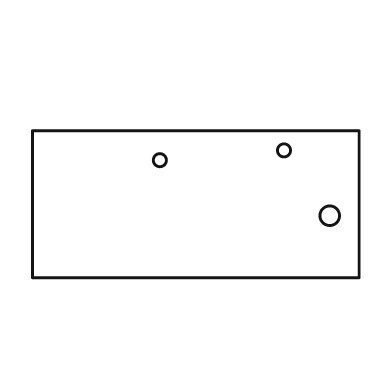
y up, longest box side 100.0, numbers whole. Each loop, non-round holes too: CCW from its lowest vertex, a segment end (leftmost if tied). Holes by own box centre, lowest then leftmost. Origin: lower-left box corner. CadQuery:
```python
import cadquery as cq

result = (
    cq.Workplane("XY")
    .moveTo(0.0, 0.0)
    .lineTo(100.0, 0.0)
    .lineTo(100.0, 45.0)
    .lineTo(0.0, 45.0)
    .close()
    .moveTo(91.0, 19.0)
    .circle(3.0)
    .moveTo(39.0, 36.0)
    .circle(2.0)
    .moveTo(77.0, 39.0)
    .circle(2.0)
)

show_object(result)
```